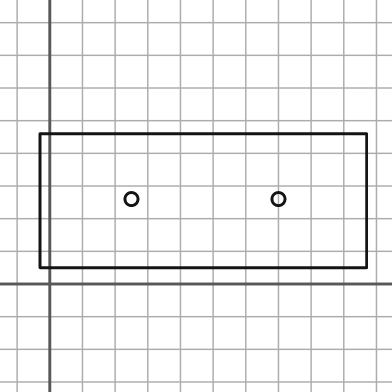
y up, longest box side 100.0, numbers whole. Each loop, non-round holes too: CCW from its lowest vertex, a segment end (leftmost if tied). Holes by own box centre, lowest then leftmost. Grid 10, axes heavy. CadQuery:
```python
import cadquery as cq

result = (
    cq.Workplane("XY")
    .moveTo(-3.0, 5.0)
    .lineTo(97.0, 5.0)
    .lineTo(97.0, 46.0)
    .lineTo(-3.0, 46.0)
    .close()
    .moveTo(25.0, 26.0)
    .circle(2.0)
    .moveTo(70.0, 26.0)
    .circle(2.0)
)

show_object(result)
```